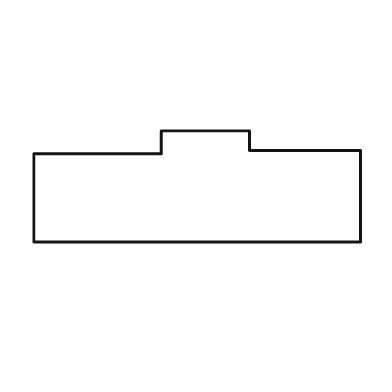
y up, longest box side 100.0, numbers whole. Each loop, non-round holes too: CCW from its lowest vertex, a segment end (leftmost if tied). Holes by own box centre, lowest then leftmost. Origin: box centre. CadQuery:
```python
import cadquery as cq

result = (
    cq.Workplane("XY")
    .moveTo(-50.0, -17.0)
    .lineTo(50.0, -17.0)
    .lineTo(50.0, 11.0)
    .lineTo(16.0, 11.0)
    .lineTo(16.0, 17.0)
    .lineTo(-11.0, 17.0)
    .lineTo(-11.0, 10.0)
    .lineTo(-50.0, 10.0)
    .close()
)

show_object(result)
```